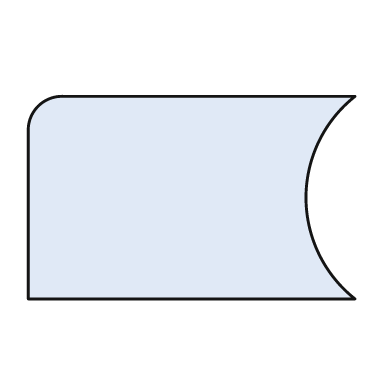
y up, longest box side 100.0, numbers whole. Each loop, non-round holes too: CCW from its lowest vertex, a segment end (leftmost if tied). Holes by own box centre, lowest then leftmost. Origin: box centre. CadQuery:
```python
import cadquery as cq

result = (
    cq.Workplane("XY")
    .moveTo(-50.0, -31.0)
    .lineTo(50.0, -31.0)
    .threePointArc((35.0, 0.0), (50.0, 31.0))
    .lineTo(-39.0, 31.0)
    .threePointArc((-47.0, 28.0), (-50.0, 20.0))
    .close()
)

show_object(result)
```